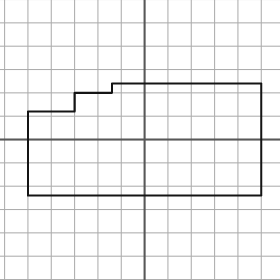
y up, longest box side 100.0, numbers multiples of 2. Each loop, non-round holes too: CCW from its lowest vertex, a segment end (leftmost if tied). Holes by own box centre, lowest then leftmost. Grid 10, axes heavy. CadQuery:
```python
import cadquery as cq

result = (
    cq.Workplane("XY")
    .moveTo(-50.0, -24.0)
    .lineTo(50.0, -24.0)
    .lineTo(50.0, 24.0)
    .lineTo(-14.0, 24.0)
    .lineTo(-14.0, 20.0)
    .lineTo(-30.0, 20.0)
    .lineTo(-30.0, 12.0)
    .lineTo(-50.0, 12.0)
    .close()
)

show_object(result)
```